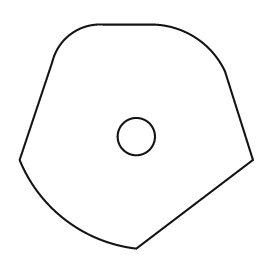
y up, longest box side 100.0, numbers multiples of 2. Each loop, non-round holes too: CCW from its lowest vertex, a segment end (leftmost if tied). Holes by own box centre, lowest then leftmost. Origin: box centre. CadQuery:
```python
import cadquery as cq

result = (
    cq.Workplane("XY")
    .moveTo(0.0, -48.0)
    .lineTo(50.0, -10.0)
    .lineTo(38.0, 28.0)
    .threePointArc((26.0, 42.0), (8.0, 48.0))
    .lineTo(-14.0, 48.0)
    .threePointArc((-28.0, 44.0), (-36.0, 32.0))
    .lineTo(-50.0, -10.0)
    .threePointArc((-30.0, -36.0), (0.0, -48.0))
    .close()
    .moveTo(0.0, 0.0)
    .circle(8.0)
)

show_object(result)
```